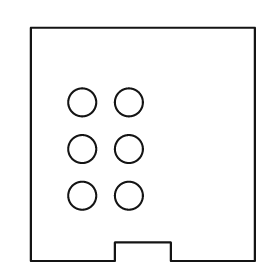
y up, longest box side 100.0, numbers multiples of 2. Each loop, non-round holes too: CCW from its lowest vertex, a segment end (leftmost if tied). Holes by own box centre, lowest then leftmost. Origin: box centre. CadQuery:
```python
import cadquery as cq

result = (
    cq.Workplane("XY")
    .moveTo(-48.0, -50.0)
    .lineTo(-12.0, -50.0)
    .lineTo(-12.0, -42.0)
    .lineTo(12.0, -42.0)
    .lineTo(12.0, -50.0)
    .lineTo(48.0, -50.0)
    .lineTo(48.0, 50.0)
    .lineTo(-48.0, 50.0)
    .close()
    .moveTo(-26.0, -22.0)
    .circle(6.0)
    .moveTo(-6.0, -22.0)
    .circle(6.0)
    .moveTo(-26.0, -2.0)
    .circle(6.0)
    .moveTo(-6.0, -2.0)
    .circle(6.0)
    .moveTo(-26.0, 18.0)
    .circle(6.0)
    .moveTo(-6.0, 18.0)
    .circle(6.0)
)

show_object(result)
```